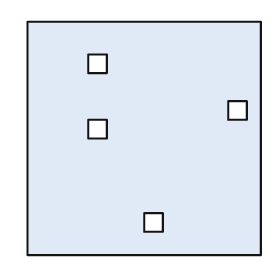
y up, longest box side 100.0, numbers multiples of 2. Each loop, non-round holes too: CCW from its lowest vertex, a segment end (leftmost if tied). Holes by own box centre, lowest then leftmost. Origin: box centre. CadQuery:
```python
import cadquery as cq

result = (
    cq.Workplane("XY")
    .moveTo(-50.0, -50.0)
    .lineTo(50.0, -50.0)
    .lineTo(50.0, 50.0)
    .lineTo(-50.0, 50.0)
    .close()
    .moveTo(0.0, -40.0)
    .lineTo(8.0, -40.0)
    .lineTo(8.0, -32.0)
    .lineTo(0.0, -32.0)
    .close()
    .moveTo(-24.0, 0.0)
    .lineTo(-16.0, 0.0)
    .lineTo(-16.0, 8.0)
    .lineTo(-24.0, 8.0)
    .close()
    .moveTo(36.0, 8.0)
    .lineTo(44.0, 8.0)
    .lineTo(44.0, 16.0)
    .lineTo(36.0, 16.0)
    .close()
    .moveTo(-24.0, 28.0)
    .lineTo(-16.0, 28.0)
    .lineTo(-16.0, 36.0)
    .lineTo(-24.0, 36.0)
    .close()
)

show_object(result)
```